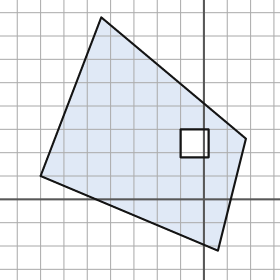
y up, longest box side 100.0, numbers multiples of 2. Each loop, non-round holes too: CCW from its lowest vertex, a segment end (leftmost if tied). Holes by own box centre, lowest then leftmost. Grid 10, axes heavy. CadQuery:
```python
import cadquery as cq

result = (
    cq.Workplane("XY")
    .moveTo(6.0, -22.0)
    .lineTo(18.0, 26.0)
    .lineTo(-44.0, 78.0)
    .lineTo(-70.0, 10.0)
    .close()
    .moveTo(-10.0, 18.0)
    .lineTo(2.0, 18.0)
    .lineTo(2.0, 30.0)
    .lineTo(-10.0, 30.0)
    .close()
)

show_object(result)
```